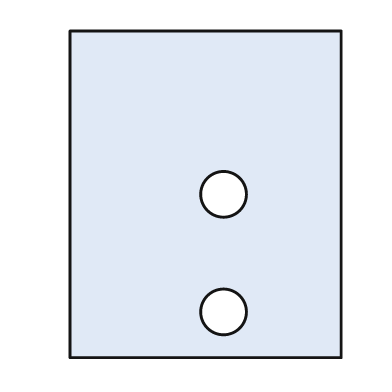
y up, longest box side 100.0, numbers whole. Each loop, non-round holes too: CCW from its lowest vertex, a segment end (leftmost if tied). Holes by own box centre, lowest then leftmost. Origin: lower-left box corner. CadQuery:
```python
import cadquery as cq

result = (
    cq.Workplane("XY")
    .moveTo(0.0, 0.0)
    .lineTo(83.0, 0.0)
    .lineTo(83.0, 100.0)
    .lineTo(0.0, 100.0)
    .close()
    .moveTo(47.0, 14.0)
    .circle(7.0)
    .moveTo(47.0, 50.0)
    .circle(7.0)
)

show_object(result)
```